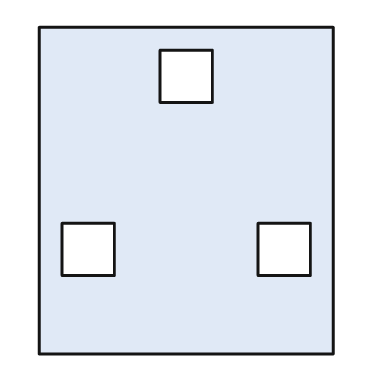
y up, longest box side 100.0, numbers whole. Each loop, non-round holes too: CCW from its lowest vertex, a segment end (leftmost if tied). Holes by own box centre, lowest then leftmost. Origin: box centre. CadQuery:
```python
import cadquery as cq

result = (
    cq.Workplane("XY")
    .moveTo(-45.0, -50.0)
    .lineTo(45.0, -50.0)
    .lineTo(45.0, 50.0)
    .lineTo(-45.0, 50.0)
    .close()
    .moveTo(-38.0, -26.0)
    .lineTo(-22.0, -26.0)
    .lineTo(-22.0, -10.0)
    .lineTo(-38.0, -10.0)
    .close()
    .moveTo(22.0, -26.0)
    .lineTo(38.0, -26.0)
    .lineTo(38.0, -10.0)
    .lineTo(22.0, -10.0)
    .close()
    .moveTo(-8.0, 27.0)
    .lineTo(8.0, 27.0)
    .lineTo(8.0, 43.0)
    .lineTo(-8.0, 43.0)
    .close()
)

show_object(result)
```